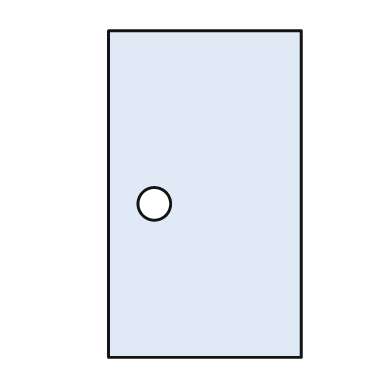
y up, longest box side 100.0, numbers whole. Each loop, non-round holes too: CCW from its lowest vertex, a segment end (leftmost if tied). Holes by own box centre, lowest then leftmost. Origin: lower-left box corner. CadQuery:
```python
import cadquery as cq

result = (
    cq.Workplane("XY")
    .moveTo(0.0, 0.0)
    .lineTo(59.0, 0.0)
    .lineTo(59.0, 100.0)
    .lineTo(0.0, 100.0)
    .close()
    .moveTo(14.0, 47.0)
    .circle(5.0)
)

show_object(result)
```